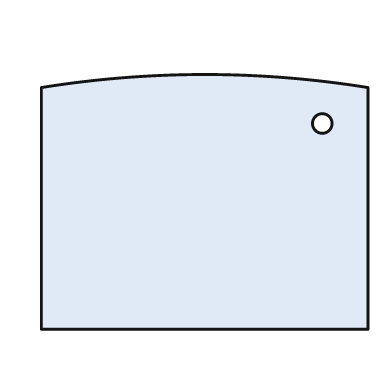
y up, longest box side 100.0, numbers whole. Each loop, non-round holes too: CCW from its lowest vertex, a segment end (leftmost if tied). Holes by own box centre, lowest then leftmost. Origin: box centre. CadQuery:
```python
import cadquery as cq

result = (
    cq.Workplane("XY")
    .moveTo(-50.0, -39.0)
    .lineTo(50.0, -39.0)
    .lineTo(50.0, 35.0)
    .threePointArc((0.0, 39.0), (-50.0, 35.0))
    .close()
    .moveTo(36.0, 24.0)
    .circle(3.0)
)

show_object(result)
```